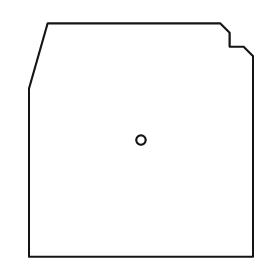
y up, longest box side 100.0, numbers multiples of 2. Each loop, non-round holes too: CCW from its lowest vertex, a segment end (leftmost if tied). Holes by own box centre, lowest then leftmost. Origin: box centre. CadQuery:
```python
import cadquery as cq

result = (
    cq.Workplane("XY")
    .moveTo(-48.0, -50.0)
    .lineTo(48.0, -50.0)
    .lineTo(48.0, 36.0)
    .lineTo(44.0, 40.0)
    .lineTo(38.0, 40.0)
    .lineTo(38.0, 46.0)
    .lineTo(34.0, 50.0)
    .lineTo(-40.0, 50.0)
    .lineTo(-48.0, 22.0)
    .close()
    .moveTo(0.0, 0.0)
    .circle(2.0)
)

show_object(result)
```